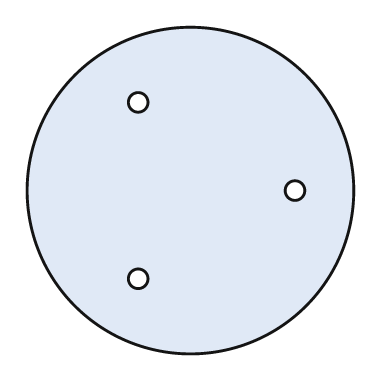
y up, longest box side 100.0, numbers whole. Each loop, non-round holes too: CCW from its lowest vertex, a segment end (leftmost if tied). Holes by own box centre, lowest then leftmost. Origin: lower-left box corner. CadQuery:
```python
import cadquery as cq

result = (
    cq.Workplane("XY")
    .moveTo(50.0, 50.0)
    .circle(50.0)
    .moveTo(34.0, 23.0)
    .circle(3.0)
    .moveTo(82.0, 50.0)
    .circle(3.0)
    .moveTo(34.0, 77.0)
    .circle(3.0)
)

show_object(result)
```